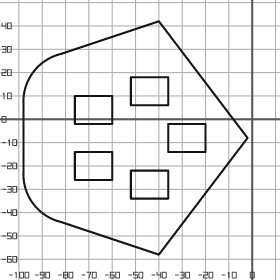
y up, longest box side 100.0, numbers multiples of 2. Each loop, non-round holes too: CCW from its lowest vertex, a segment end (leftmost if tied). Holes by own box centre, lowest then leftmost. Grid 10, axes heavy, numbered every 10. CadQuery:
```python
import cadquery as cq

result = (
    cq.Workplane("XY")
    .moveTo(-40.0, -58.0)
    .lineTo(-2.0, -8.0)
    .lineTo(-40.0, 42.0)
    .lineTo(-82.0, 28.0)
    .threePointArc((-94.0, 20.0), (-98.0, 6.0))
    .lineTo(-98.0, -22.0)
    .threePointArc((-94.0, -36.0), (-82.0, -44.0))
    .close()
    .moveTo(-52.0, -34.0)
    .lineTo(-36.0, -34.0)
    .lineTo(-36.0, -22.0)
    .lineTo(-52.0, -22.0)
    .close()
    .moveTo(-76.0, -26.0)
    .lineTo(-60.0, -26.0)
    .lineTo(-60.0, -14.0)
    .lineTo(-76.0, -14.0)
    .close()
    .moveTo(-36.0, -14.0)
    .lineTo(-20.0, -14.0)
    .lineTo(-20.0, -2.0)
    .lineTo(-36.0, -2.0)
    .close()
    .moveTo(-76.0, -2.0)
    .lineTo(-60.0, -2.0)
    .lineTo(-60.0, 10.0)
    .lineTo(-76.0, 10.0)
    .close()
    .moveTo(-52.0, 6.0)
    .lineTo(-36.0, 6.0)
    .lineTo(-36.0, 18.0)
    .lineTo(-52.0, 18.0)
    .close()
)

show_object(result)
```